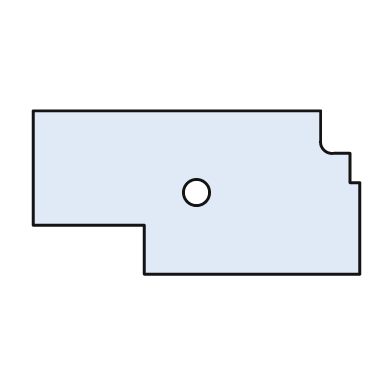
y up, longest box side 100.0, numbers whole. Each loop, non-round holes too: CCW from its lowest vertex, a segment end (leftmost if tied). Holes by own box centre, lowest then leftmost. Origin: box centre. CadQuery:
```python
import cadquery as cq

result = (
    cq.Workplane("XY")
    .moveTo(-16.0, -25.0)
    .lineTo(50.0, -25.0)
    .lineTo(50.0, 3.0)
    .lineTo(47.0, 3.0)
    .lineTo(47.0, 12.0)
    .lineTo(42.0, 12.0)
    .threePointArc((39.0, 13.0), (38.0, 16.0))
    .lineTo(38.0, 25.0)
    .lineTo(-50.0, 25.0)
    .lineTo(-50.0, -10.0)
    .lineTo(-16.0, -10.0)
    .close()
    .moveTo(0.0, 0.0)
    .circle(4.0)
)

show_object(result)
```